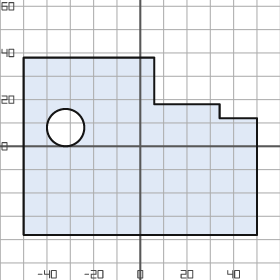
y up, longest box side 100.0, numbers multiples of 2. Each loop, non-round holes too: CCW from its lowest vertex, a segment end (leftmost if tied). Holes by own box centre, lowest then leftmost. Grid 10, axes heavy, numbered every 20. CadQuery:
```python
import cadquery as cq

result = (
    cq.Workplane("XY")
    .moveTo(-50.0, -38.0)
    .lineTo(50.0, -38.0)
    .lineTo(50.0, 12.0)
    .lineTo(34.0, 12.0)
    .lineTo(34.0, 18.0)
    .lineTo(6.0, 18.0)
    .lineTo(6.0, 38.0)
    .lineTo(-50.0, 38.0)
    .close()
    .moveTo(-32.0, 8.0)
    .circle(8.0)
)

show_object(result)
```